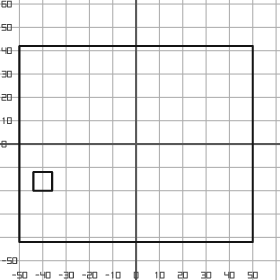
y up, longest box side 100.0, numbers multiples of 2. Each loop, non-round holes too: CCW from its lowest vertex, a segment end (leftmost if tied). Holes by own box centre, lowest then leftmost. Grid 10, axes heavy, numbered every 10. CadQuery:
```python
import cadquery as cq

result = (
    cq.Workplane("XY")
    .moveTo(-50.0, -42.0)
    .lineTo(50.0, -42.0)
    .lineTo(50.0, 42.0)
    .lineTo(-50.0, 42.0)
    .close()
    .moveTo(-44.0, -20.0)
    .lineTo(-36.0, -20.0)
    .lineTo(-36.0, -12.0)
    .lineTo(-44.0, -12.0)
    .close()
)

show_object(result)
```